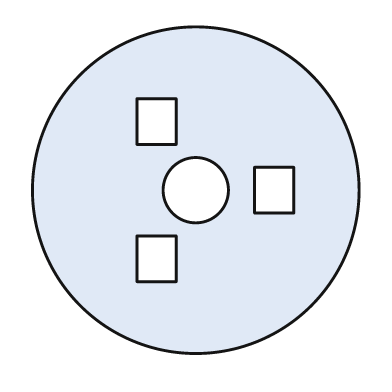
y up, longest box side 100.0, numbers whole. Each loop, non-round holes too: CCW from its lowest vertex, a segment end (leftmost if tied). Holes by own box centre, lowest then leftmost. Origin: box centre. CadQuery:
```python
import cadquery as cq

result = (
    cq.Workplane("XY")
    .moveTo(0.0, 0.0)
    .circle(50.0)
    .moveTo(-18.0, -28.0)
    .lineTo(-6.0, -28.0)
    .lineTo(-6.0, -14.0)
    .lineTo(-18.0, -14.0)
    .close()
    .moveTo(0.0, 0.0)
    .circle(10.0)
    .moveTo(18.0, -7.0)
    .lineTo(30.0, -7.0)
    .lineTo(30.0, 7.0)
    .lineTo(18.0, 7.0)
    .close()
    .moveTo(-18.0, 14.0)
    .lineTo(-6.0, 14.0)
    .lineTo(-6.0, 28.0)
    .lineTo(-18.0, 28.0)
    .close()
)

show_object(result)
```